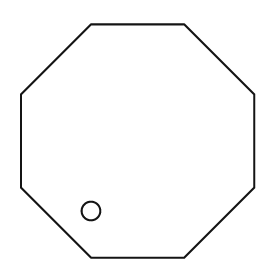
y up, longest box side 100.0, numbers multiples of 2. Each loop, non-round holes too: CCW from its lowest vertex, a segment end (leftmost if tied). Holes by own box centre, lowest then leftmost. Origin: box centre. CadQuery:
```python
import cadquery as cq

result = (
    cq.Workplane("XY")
    .moveTo(-20.0, -50.0)
    .lineTo(20.0, -50.0)
    .lineTo(50.0, -20.0)
    .lineTo(50.0, 20.0)
    .lineTo(20.0, 50.0)
    .lineTo(-20.0, 50.0)
    .lineTo(-50.0, 20.0)
    .lineTo(-50.0, -20.0)
    .close()
    .moveTo(-20.0, -30.0)
    .circle(4.0)
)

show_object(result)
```